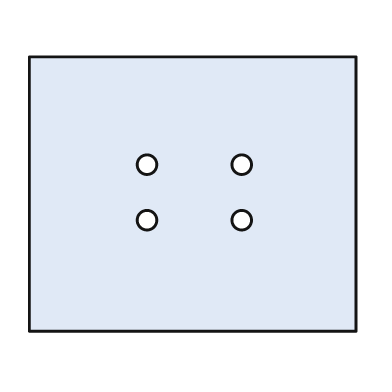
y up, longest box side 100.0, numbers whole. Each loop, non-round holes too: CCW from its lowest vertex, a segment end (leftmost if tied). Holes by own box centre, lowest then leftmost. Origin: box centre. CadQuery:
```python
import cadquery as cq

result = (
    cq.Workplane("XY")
    .moveTo(-50.0, -42.0)
    .lineTo(50.0, -42.0)
    .lineTo(50.0, 42.0)
    .lineTo(-50.0, 42.0)
    .close()
    .moveTo(-14.0, -8.0)
    .circle(3.0)
    .moveTo(15.0, -8.0)
    .circle(3.0)
    .moveTo(-14.0, 9.0)
    .circle(3.0)
    .moveTo(15.0, 9.0)
    .circle(3.0)
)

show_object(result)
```